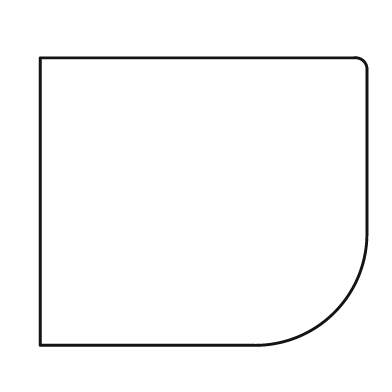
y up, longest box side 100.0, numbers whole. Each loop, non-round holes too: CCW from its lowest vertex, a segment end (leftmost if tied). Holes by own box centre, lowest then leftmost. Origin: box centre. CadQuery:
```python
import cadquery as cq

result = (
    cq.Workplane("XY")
    .moveTo(-50.0, -44.0)
    .lineTo(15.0, -44.0)
    .threePointArc((40.0, -34.0), (50.0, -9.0))
    .lineTo(50.0, 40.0)
    .threePointArc((49.0, 43.0), (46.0, 44.0))
    .lineTo(-50.0, 44.0)
    .close()
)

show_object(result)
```